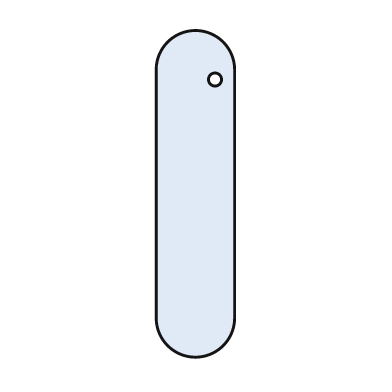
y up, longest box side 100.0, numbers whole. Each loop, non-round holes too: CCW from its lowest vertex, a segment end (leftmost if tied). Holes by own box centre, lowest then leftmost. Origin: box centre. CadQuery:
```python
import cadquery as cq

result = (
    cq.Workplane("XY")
    .moveTo(-12.0, -38.0)
    .threePointArc((0.0, -50.0), (12.0, -38.0))
    .lineTo(12.0, 38.0)
    .threePointArc((0.0, 50.0), (-12.0, 38.0))
    .close()
    .moveTo(6.0, 35.0)
    .circle(2.0)
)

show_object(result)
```